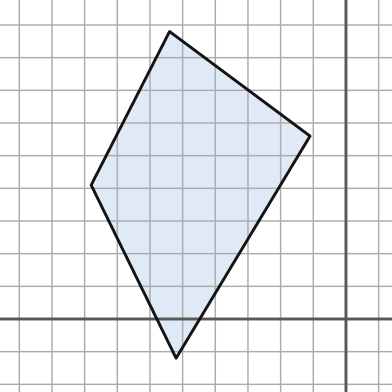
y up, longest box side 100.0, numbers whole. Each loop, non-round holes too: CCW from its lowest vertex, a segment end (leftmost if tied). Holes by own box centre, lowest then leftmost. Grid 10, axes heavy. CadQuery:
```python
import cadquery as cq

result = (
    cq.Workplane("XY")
    .moveTo(-52.0, -12.0)
    .lineTo(-11.0, 56.0)
    .lineTo(-54.0, 88.0)
    .lineTo(-78.0, 41.0)
    .close()
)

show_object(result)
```